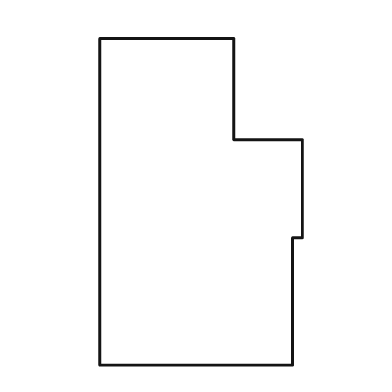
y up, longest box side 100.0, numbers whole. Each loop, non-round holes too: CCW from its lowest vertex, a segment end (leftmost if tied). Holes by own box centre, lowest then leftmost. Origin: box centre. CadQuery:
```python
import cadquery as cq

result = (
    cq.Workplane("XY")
    .moveTo(-31.0, -50.0)
    .lineTo(28.0, -50.0)
    .lineTo(28.0, -11.0)
    .lineTo(31.0, -11.0)
    .lineTo(31.0, 19.0)
    .lineTo(10.0, 19.0)
    .lineTo(10.0, 50.0)
    .lineTo(-31.0, 50.0)
    .close()
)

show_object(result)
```